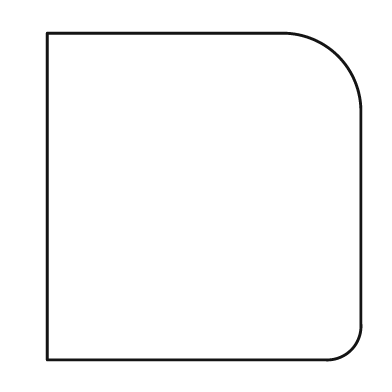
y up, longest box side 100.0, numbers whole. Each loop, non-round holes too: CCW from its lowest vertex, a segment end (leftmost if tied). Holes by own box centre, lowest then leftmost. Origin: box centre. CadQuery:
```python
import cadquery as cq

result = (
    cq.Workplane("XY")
    .moveTo(-48.0, -50.0)
    .lineTo(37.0, -50.0)
    .threePointArc((45.0, -47.0), (48.0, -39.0))
    .lineTo(48.0, 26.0)
    .threePointArc((41.0, 43.0), (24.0, 50.0))
    .lineTo(-48.0, 50.0)
    .close()
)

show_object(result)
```